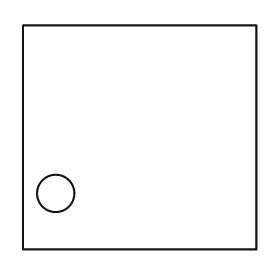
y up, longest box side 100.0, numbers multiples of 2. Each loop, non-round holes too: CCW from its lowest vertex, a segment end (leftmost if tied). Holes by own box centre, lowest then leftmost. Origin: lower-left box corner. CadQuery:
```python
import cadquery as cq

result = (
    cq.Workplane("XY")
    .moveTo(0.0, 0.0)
    .lineTo(100.0, 0.0)
    .lineTo(100.0, 96.0)
    .lineTo(0.0, 96.0)
    .close()
    .moveTo(14.0, 24.0)
    .circle(8.0)
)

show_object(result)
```